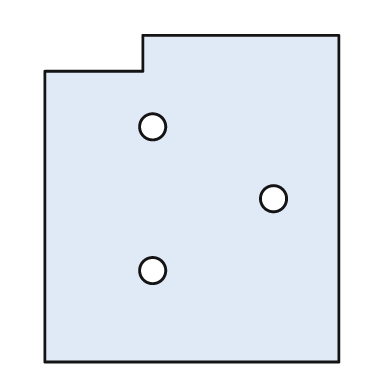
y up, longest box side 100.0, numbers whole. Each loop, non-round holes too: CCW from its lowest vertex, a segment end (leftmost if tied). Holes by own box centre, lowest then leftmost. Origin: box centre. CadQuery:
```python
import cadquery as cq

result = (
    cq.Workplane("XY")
    .moveTo(-45.0, -50.0)
    .lineTo(45.0, -50.0)
    .lineTo(45.0, 50.0)
    .lineTo(-15.0, 50.0)
    .lineTo(-15.0, 39.0)
    .lineTo(-45.0, 39.0)
    .close()
    .moveTo(-12.0, -22.0)
    .circle(4.0)
    .moveTo(25.0, 0.0)
    .circle(4.0)
    .moveTo(-12.0, 22.0)
    .circle(4.0)
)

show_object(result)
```